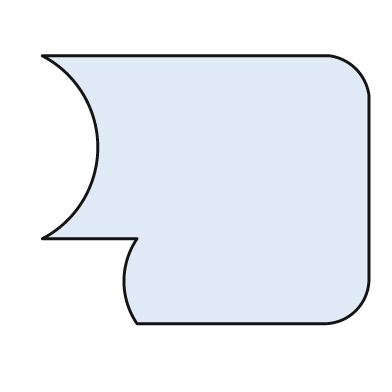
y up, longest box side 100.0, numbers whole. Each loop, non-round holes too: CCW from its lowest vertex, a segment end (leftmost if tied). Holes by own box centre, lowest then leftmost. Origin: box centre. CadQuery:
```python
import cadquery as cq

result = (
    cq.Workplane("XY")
    .moveTo(-21.0, -41.0)
    .lineTo(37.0, -41.0)
    .threePointArc((46.0, -37.0), (50.0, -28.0))
    .lineTo(50.0, 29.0)
    .threePointArc((46.0, 37.0), (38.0, 41.0))
    .lineTo(-50.0, 41.0)
    .threePointArc((-33.0, 13.0), (-50.0, -15.0))
    .lineTo(-21.0, -15.0)
    .threePointArc((-25.0, -28.0), (-21.0, -41.0))
    .close()
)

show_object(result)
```